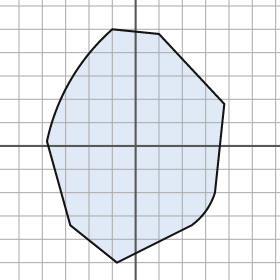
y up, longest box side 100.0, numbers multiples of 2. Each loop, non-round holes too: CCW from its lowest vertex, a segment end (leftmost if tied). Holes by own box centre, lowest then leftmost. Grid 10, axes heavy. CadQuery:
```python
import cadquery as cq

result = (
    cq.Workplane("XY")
    .moveTo(-8.0, -50.0)
    .lineTo(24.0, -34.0)
    .threePointArc((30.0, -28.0), (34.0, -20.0))
    .lineTo(38.0, 18.0)
    .lineTo(10.0, 48.0)
    .lineTo(-10.0, 50.0)
    .threePointArc((-28.0, 28.0), (-38.0, 2.0))
    .lineTo(-28.0, -34.0)
    .close()
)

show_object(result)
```